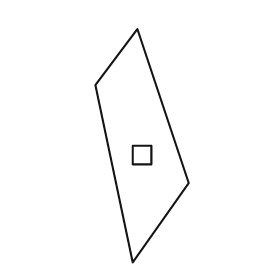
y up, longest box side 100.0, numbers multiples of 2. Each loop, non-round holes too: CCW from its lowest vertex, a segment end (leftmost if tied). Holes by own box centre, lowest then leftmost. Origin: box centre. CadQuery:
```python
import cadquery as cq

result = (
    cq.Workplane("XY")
    .moveTo(-4.0, -50.0)
    .lineTo(20.0, -16.0)
    .lineTo(-2.0, 50.0)
    .lineTo(-20.0, 26.0)
    .close()
    .moveTo(-4.0, -8.0)
    .lineTo(4.0, -8.0)
    .lineTo(4.0, 0.0)
    .lineTo(-4.0, 0.0)
    .close()
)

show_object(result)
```